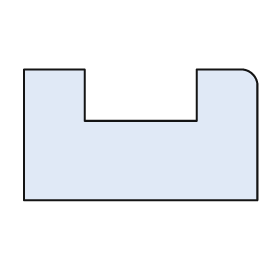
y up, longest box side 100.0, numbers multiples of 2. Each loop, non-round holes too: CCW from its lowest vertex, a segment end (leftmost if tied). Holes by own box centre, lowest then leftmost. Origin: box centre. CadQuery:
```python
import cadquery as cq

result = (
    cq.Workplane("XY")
    .moveTo(-50.0, -28.0)
    .lineTo(50.0, -28.0)
    .lineTo(50.0, 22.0)
    .threePointArc((48.0, 26.0), (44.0, 28.0))
    .lineTo(24.0, 28.0)
    .lineTo(24.0, 6.0)
    .lineTo(-24.0, 6.0)
    .lineTo(-24.0, 28.0)
    .lineTo(-50.0, 28.0)
    .close()
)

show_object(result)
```